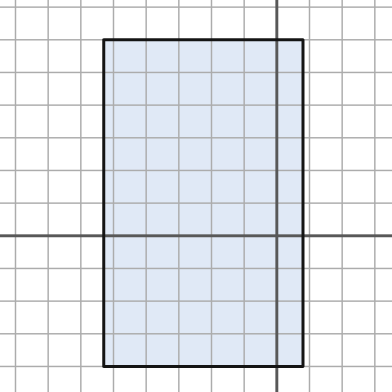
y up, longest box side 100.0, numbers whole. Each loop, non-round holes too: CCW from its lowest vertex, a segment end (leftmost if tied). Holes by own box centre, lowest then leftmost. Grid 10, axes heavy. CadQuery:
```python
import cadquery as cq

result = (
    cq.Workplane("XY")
    .moveTo(-53.0, -40.0)
    .lineTo(8.0, -40.0)
    .lineTo(8.0, 60.0)
    .lineTo(-53.0, 60.0)
    .close()
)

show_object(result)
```